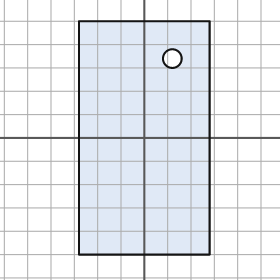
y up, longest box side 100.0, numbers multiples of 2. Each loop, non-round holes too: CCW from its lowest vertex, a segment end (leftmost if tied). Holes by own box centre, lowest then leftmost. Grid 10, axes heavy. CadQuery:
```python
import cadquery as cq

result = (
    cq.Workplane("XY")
    .moveTo(-28.0, -50.0)
    .lineTo(28.0, -50.0)
    .lineTo(28.0, 50.0)
    .lineTo(-28.0, 50.0)
    .close()
    .moveTo(12.0, 34.0)
    .circle(4.0)
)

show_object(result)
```